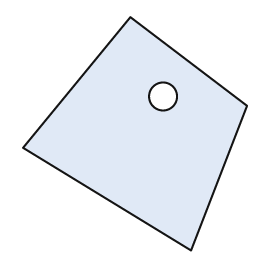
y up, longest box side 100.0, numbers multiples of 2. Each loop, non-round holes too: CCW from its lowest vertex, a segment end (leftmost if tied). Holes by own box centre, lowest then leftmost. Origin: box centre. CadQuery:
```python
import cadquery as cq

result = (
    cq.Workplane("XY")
    .moveTo(24.0, -50.0)
    .lineTo(48.0, 12.0)
    .lineTo(-2.0, 50.0)
    .lineTo(-48.0, -6.0)
    .close()
    .moveTo(12.0, 16.0)
    .circle(6.0)
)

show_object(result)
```